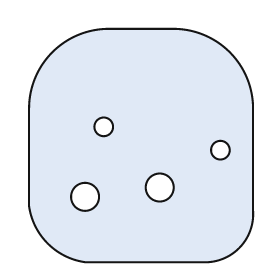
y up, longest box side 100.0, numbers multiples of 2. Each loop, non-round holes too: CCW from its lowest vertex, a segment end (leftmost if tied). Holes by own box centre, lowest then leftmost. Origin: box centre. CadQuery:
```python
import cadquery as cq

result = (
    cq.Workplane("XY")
    .moveTo(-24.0, -50.0)
    .lineTo(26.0, -50.0)
    .threePointArc((42.0, -44.0), (48.0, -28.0))
    .lineTo(48.0, 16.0)
    .threePointArc((38.0, 40.0), (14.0, 50.0))
    .lineTo(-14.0, 50.0)
    .threePointArc((-38.0, 40.0), (-48.0, 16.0))
    .lineTo(-48.0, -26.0)
    .threePointArc((-40.0, -42.0), (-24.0, -50.0))
    .close()
    .moveTo(-24.0, -22.0)
    .circle(6.0)
    .moveTo(8.0, -18.0)
    .circle(6.0)
    .moveTo(34.0, -2.0)
    .circle(4.0)
    .moveTo(-16.0, 8.0)
    .circle(4.0)
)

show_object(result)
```